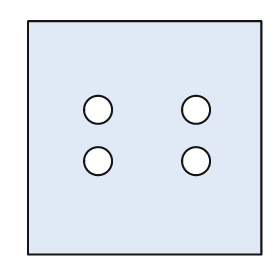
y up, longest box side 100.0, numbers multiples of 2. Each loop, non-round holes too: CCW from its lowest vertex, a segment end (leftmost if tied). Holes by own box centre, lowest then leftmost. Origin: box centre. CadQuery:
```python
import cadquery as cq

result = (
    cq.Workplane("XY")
    .moveTo(-50.0, -50.0)
    .lineTo(50.0, -50.0)
    .lineTo(50.0, 50.0)
    .lineTo(-50.0, 50.0)
    .close()
    .moveTo(-20.0, -10.0)
    .circle(6.0)
    .moveTo(22.0, -10.0)
    .circle(6.0)
    .moveTo(-20.0, 12.0)
    .circle(6.0)
    .moveTo(22.0, 12.0)
    .circle(6.0)
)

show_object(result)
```